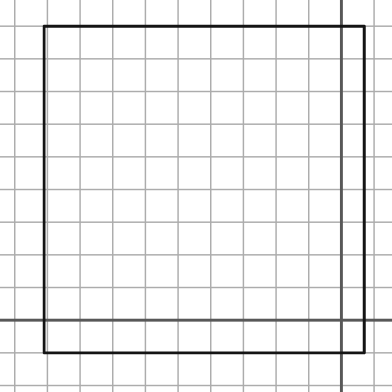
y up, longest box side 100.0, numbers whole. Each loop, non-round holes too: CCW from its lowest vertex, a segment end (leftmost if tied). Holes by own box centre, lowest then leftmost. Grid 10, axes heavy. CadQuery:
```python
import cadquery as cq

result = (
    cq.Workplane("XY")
    .moveTo(-91.0, -10.0)
    .lineTo(7.0, -10.0)
    .lineTo(7.0, 90.0)
    .lineTo(-91.0, 90.0)
    .close()
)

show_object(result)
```